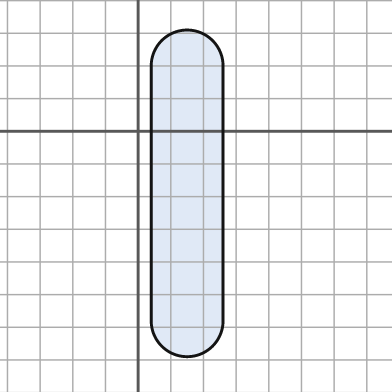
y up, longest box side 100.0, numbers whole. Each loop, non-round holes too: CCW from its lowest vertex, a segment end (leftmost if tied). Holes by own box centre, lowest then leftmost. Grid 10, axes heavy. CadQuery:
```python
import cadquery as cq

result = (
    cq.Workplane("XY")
    .moveTo(4.0, -58.0)
    .threePointArc((15.0, -69.0), (26.0, -58.0))
    .lineTo(26.0, 20.0)
    .threePointArc((15.0, 31.0), (4.0, 20.0))
    .close()
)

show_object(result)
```